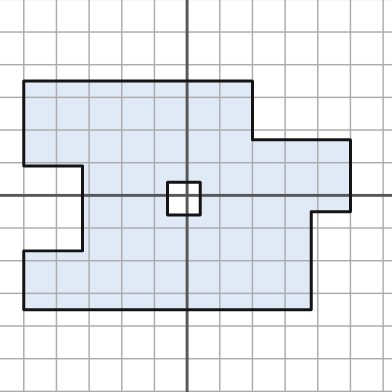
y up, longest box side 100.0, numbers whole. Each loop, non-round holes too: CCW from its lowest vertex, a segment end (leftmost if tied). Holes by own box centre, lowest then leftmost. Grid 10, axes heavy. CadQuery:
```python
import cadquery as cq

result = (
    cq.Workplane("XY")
    .moveTo(-50.0, -35.0)
    .lineTo(38.0, -35.0)
    .lineTo(38.0, -5.0)
    .lineTo(50.0, -5.0)
    .lineTo(50.0, 17.0)
    .lineTo(20.0, 17.0)
    .lineTo(20.0, 35.0)
    .lineTo(-50.0, 35.0)
    .lineTo(-50.0, 9.0)
    .lineTo(-32.0, 9.0)
    .lineTo(-32.0, -17.0)
    .lineTo(-50.0, -17.0)
    .close()
    .moveTo(-6.0, -6.0)
    .lineTo(4.0, -6.0)
    .lineTo(4.0, 4.0)
    .lineTo(-6.0, 4.0)
    .close()
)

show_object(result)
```